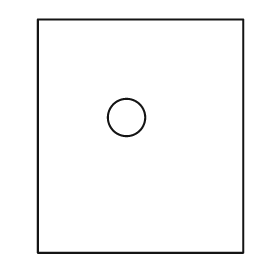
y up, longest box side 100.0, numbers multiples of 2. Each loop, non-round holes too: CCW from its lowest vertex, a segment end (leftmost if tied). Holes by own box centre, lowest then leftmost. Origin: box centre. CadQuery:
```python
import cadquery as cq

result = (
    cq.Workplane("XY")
    .moveTo(-44.0, -50.0)
    .lineTo(44.0, -50.0)
    .lineTo(44.0, 50.0)
    .lineTo(-44.0, 50.0)
    .close()
    .moveTo(-6.0, 8.0)
    .circle(8.0)
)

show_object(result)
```